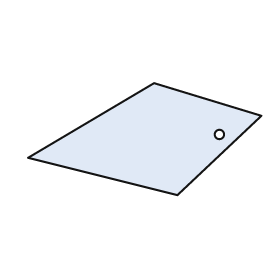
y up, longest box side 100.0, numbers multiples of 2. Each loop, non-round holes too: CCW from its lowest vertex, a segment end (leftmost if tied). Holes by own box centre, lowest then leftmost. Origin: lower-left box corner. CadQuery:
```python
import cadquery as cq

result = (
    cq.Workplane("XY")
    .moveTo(64.0, 0.0)
    .lineTo(100.0, 34.0)
    .lineTo(54.0, 48.0)
    .lineTo(0.0, 16.0)
    .close()
    .moveTo(82.0, 26.0)
    .circle(2.0)
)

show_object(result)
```